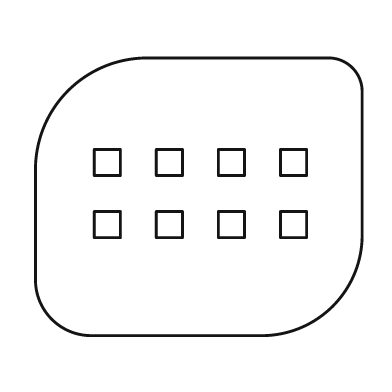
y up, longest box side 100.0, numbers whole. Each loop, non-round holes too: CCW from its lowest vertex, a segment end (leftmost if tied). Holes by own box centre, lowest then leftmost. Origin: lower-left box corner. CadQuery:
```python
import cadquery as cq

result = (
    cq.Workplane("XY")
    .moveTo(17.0, 0.0)
    .lineTo(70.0, 0.0)
    .threePointArc((91.0, 9.0), (100.0, 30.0))
    .lineTo(100.0, 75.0)
    .threePointArc((97.0, 82.0), (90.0, 85.0))
    .lineTo(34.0, 85.0)
    .threePointArc((10.0, 75.0), (0.0, 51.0))
    .lineTo(0.0, 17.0)
    .threePointArc((5.0, 5.0), (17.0, 0.0))
    .close()
    .moveTo(18.0, 30.0)
    .lineTo(26.0, 30.0)
    .lineTo(26.0, 38.0)
    .lineTo(18.0, 38.0)
    .close()
    .moveTo(37.0, 30.0)
    .lineTo(45.0, 30.0)
    .lineTo(45.0, 38.0)
    .lineTo(37.0, 38.0)
    .close()
    .moveTo(56.0, 30.0)
    .lineTo(64.0, 30.0)
    .lineTo(64.0, 38.0)
    .lineTo(56.0, 38.0)
    .close()
    .moveTo(75.0, 30.0)
    .lineTo(83.0, 30.0)
    .lineTo(83.0, 38.0)
    .lineTo(75.0, 38.0)
    .close()
    .moveTo(18.0, 49.0)
    .lineTo(26.0, 49.0)
    .lineTo(26.0, 57.0)
    .lineTo(18.0, 57.0)
    .close()
    .moveTo(37.0, 49.0)
    .lineTo(45.0, 49.0)
    .lineTo(45.0, 57.0)
    .lineTo(37.0, 57.0)
    .close()
    .moveTo(56.0, 49.0)
    .lineTo(64.0, 49.0)
    .lineTo(64.0, 57.0)
    .lineTo(56.0, 57.0)
    .close()
    .moveTo(75.0, 49.0)
    .lineTo(83.0, 49.0)
    .lineTo(83.0, 57.0)
    .lineTo(75.0, 57.0)
    .close()
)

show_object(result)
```